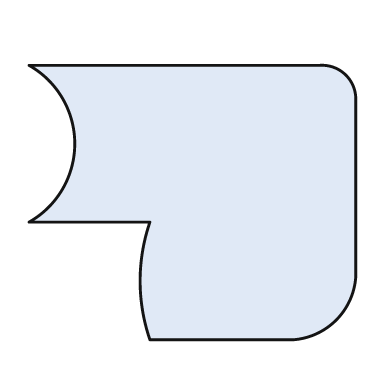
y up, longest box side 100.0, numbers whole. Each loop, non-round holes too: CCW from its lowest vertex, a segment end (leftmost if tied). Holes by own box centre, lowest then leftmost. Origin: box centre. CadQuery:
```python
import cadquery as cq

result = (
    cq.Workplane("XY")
    .moveTo(-13.0, -42.0)
    .lineTo(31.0, -42.0)
    .threePointArc((44.0, -36.0), (50.0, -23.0))
    .lineTo(50.0, 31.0)
    .threePointArc((47.0, 39.0), (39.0, 42.0))
    .lineTo(-50.0, 42.0)
    .threePointArc((-36.0, 18.0), (-50.0, -6.0))
    .lineTo(-13.0, -6.0)
    .threePointArc((-16.0, -24.0), (-13.0, -42.0))
    .close()
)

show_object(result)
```